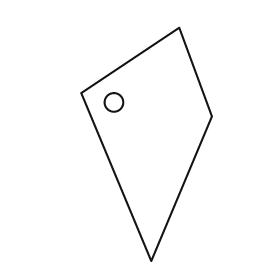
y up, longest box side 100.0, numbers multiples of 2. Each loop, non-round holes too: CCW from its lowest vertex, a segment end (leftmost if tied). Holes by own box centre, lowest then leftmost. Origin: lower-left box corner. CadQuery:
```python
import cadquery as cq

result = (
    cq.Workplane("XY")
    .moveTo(30.0, 0.0)
    .lineTo(56.0, 62.0)
    .lineTo(42.0, 100.0)
    .lineTo(0.0, 72.0)
    .close()
    .moveTo(14.0, 68.0)
    .circle(4.0)
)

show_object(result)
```